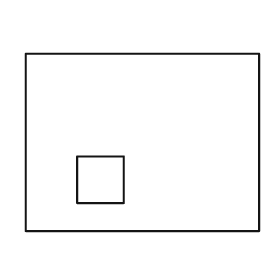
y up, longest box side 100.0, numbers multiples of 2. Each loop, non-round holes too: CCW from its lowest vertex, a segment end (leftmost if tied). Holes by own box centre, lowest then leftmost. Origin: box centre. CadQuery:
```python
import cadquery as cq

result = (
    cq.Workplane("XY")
    .moveTo(-50.0, -38.0)
    .lineTo(50.0, -38.0)
    .lineTo(50.0, 38.0)
    .lineTo(-50.0, 38.0)
    .close()
    .moveTo(-28.0, -26.0)
    .lineTo(-8.0, -26.0)
    .lineTo(-8.0, -6.0)
    .lineTo(-28.0, -6.0)
    .close()
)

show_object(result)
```